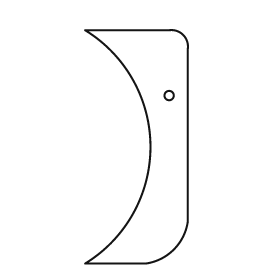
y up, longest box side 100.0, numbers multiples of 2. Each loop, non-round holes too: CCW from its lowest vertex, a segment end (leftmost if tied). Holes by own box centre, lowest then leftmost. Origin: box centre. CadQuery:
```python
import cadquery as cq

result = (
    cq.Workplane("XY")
    .moveTo(-22.0, -50.0)
    .lineTo(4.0, -50.0)
    .threePointArc((16.0, -44.0), (22.0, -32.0))
    .lineTo(22.0, 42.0)
    .threePointArc((20.0, 48.0), (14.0, 50.0))
    .lineTo(-22.0, 50.0)
    .threePointArc((6.0, 0.0), (-22.0, -50.0))
    .close()
    .moveTo(14.0, 22.0)
    .circle(2.0)
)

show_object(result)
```